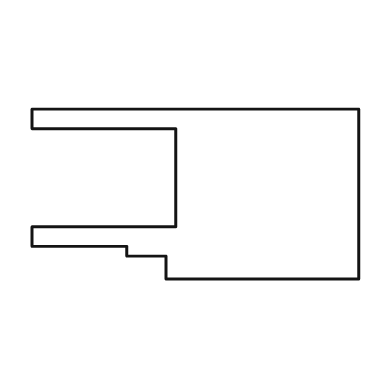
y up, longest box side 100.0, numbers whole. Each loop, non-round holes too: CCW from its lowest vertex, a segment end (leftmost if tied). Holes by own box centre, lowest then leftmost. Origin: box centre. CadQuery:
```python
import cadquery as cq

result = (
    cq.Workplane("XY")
    .moveTo(-9.0, -26.0)
    .lineTo(50.0, -26.0)
    .lineTo(50.0, 26.0)
    .lineTo(-50.0, 26.0)
    .lineTo(-50.0, 20.0)
    .lineTo(-6.0, 20.0)
    .lineTo(-6.0, -10.0)
    .lineTo(-50.0, -10.0)
    .lineTo(-50.0, -16.0)
    .lineTo(-21.0, -16.0)
    .lineTo(-21.0, -19.0)
    .lineTo(-9.0, -19.0)
    .close()
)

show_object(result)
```